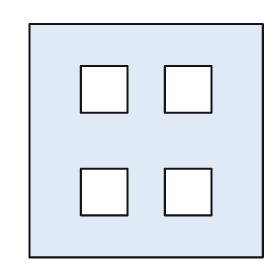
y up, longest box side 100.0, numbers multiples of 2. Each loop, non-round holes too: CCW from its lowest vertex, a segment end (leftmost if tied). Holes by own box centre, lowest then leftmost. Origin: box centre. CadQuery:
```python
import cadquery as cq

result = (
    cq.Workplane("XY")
    .moveTo(-50.0, -50.0)
    .lineTo(50.0, -50.0)
    .lineTo(50.0, 50.0)
    .lineTo(-50.0, 50.0)
    .close()
    .moveTo(-28.0, -32.0)
    .lineTo(-8.0, -32.0)
    .lineTo(-8.0, -12.0)
    .lineTo(-28.0, -12.0)
    .close()
    .moveTo(8.0, -32.0)
    .lineTo(28.0, -32.0)
    .lineTo(28.0, -12.0)
    .lineTo(8.0, -12.0)
    .close()
    .moveTo(-28.0, 12.0)
    .lineTo(-8.0, 12.0)
    .lineTo(-8.0, 32.0)
    .lineTo(-28.0, 32.0)
    .close()
    .moveTo(8.0, 12.0)
    .lineTo(28.0, 12.0)
    .lineTo(28.0, 32.0)
    .lineTo(8.0, 32.0)
    .close()
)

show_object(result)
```